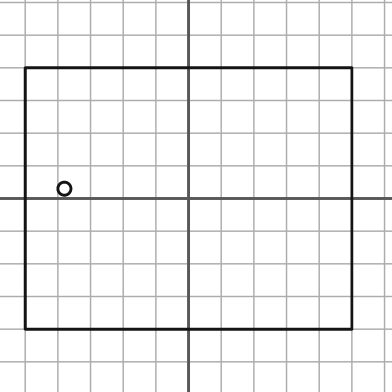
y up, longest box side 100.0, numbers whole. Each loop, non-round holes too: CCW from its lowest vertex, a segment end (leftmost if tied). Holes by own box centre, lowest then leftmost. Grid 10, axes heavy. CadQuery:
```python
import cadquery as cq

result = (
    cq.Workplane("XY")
    .moveTo(-50.0, -40.0)
    .lineTo(50.0, -40.0)
    .lineTo(50.0, 40.0)
    .lineTo(-50.0, 40.0)
    .close()
    .moveTo(-38.0, 3.0)
    .circle(2.0)
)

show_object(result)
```